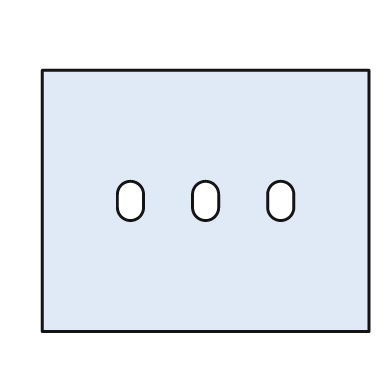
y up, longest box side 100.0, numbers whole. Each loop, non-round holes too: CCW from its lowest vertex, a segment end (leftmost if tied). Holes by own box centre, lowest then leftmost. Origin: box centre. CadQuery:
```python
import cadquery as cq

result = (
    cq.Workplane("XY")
    .moveTo(-50.0, -40.0)
    .lineTo(50.0, -40.0)
    .lineTo(50.0, 40.0)
    .lineTo(-50.0, 40.0)
    .close()
    .moveTo(-27.0, -2.0)
    .threePointArc((-23.0, -6.0), (-19.0, -2.0))
    .lineTo(-19.0, 2.0)
    .threePointArc((-23.0, 6.0), (-27.0, 2.0))
    .close()
    .moveTo(-4.0, -2.0)
    .threePointArc((0.0, -6.0), (4.0, -2.0))
    .lineTo(4.0, 2.0)
    .threePointArc((0.0, 6.0), (-4.0, 2.0))
    .close()
    .moveTo(19.0, -2.0)
    .threePointArc((23.0, -6.0), (27.0, -2.0))
    .lineTo(27.0, 2.0)
    .threePointArc((23.0, 6.0), (19.0, 2.0))
    .close()
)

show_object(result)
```